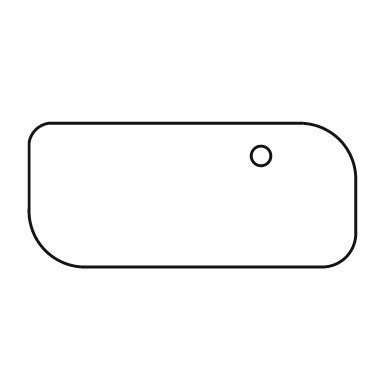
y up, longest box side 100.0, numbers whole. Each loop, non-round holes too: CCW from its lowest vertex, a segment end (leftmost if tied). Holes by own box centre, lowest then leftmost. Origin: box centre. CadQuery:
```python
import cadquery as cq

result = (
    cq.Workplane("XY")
    .moveTo(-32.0, -22.0)
    .lineTo(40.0, -22.0)
    .threePointArc((47.0, -19.0), (50.0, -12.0))
    .lineTo(50.0, 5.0)
    .threePointArc((45.0, 17.0), (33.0, 22.0))
    .lineTo(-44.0, 22.0)
    .threePointArc((-48.0, 20.0), (-50.0, 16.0))
    .lineTo(-50.0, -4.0)
    .threePointArc((-45.0, -17.0), (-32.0, -22.0))
    .close()
    .moveTo(21.0, 12.0)
    .circle(3.0)
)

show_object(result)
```